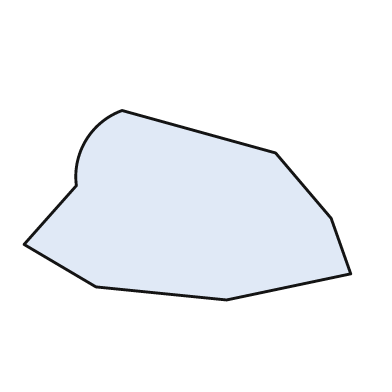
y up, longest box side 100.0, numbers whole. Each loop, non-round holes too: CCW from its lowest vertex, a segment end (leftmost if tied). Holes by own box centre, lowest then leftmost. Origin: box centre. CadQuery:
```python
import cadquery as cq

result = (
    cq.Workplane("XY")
    .moveTo(12.0, -29.0)
    .lineTo(50.0, -21.0)
    .lineTo(44.0, -4.0)
    .lineTo(27.0, 16.0)
    .lineTo(-20.0, 29.0)
    .threePointArc((-31.0, 20.0), (-34.0, 6.0))
    .lineTo(-50.0, -12.0)
    .lineTo(-28.0, -25.0)
    .close()
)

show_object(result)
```